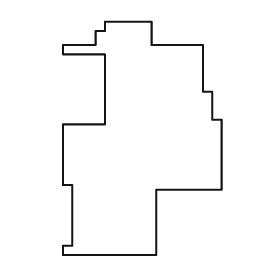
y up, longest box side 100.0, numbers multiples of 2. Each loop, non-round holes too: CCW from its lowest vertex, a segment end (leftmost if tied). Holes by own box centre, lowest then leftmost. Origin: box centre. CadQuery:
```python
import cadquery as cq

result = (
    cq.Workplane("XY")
    .moveTo(-34.0, -50.0)
    .lineTo(6.0, -50.0)
    .lineTo(6.0, -22.0)
    .lineTo(34.0, -22.0)
    .lineTo(34.0, 8.0)
    .lineTo(30.0, 8.0)
    .lineTo(30.0, 20.0)
    .lineTo(26.0, 20.0)
    .lineTo(26.0, 40.0)
    .lineTo(4.0, 40.0)
    .lineTo(4.0, 50.0)
    .lineTo(-16.0, 50.0)
    .lineTo(-16.0, 46.0)
    .lineTo(-20.0, 46.0)
    .lineTo(-20.0, 40.0)
    .lineTo(-34.0, 40.0)
    .lineTo(-34.0, 36.0)
    .lineTo(-16.0, 36.0)
    .lineTo(-16.0, 6.0)
    .lineTo(-34.0, 6.0)
    .lineTo(-34.0, -20.0)
    .lineTo(-30.0, -20.0)
    .lineTo(-30.0, -46.0)
    .lineTo(-34.0, -46.0)
    .close()
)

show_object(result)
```